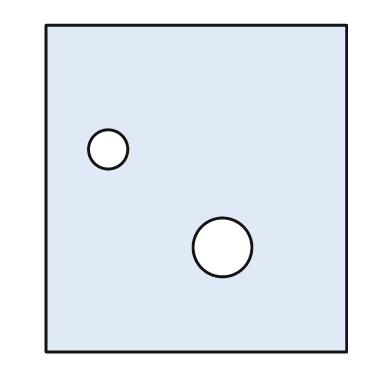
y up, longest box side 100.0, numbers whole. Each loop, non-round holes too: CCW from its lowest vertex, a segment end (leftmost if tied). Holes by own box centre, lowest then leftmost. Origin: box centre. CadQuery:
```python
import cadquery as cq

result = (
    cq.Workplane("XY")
    .moveTo(-46.0, -50.0)
    .lineTo(46.0, -50.0)
    .lineTo(46.0, 50.0)
    .lineTo(-46.0, 50.0)
    .close()
    .moveTo(8.0, -18.0)
    .circle(9.0)
    .moveTo(-27.0, 12.0)
    .circle(6.0)
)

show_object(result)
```